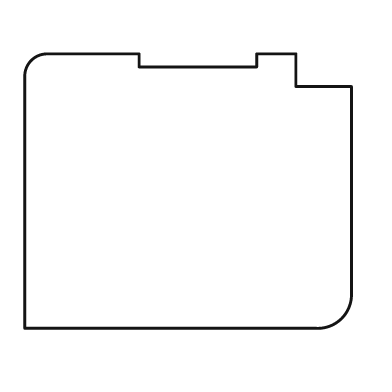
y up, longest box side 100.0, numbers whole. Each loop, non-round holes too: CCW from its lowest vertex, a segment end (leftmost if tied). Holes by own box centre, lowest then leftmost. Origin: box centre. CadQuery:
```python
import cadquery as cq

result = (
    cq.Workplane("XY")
    .moveTo(-50.0, -42.0)
    .lineTo(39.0, -42.0)
    .threePointArc((47.0, -39.0), (50.0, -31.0))
    .lineTo(50.0, 32.0)
    .lineTo(33.0, 32.0)
    .lineTo(33.0, 42.0)
    .lineTo(21.0, 42.0)
    .lineTo(21.0, 38.0)
    .lineTo(-15.0, 38.0)
    .lineTo(-15.0, 42.0)
    .lineTo(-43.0, 42.0)
    .threePointArc((-48.0, 40.0), (-50.0, 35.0))
    .close()
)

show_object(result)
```